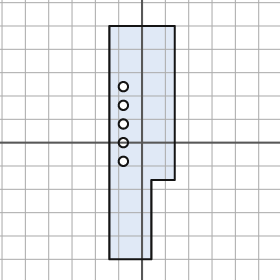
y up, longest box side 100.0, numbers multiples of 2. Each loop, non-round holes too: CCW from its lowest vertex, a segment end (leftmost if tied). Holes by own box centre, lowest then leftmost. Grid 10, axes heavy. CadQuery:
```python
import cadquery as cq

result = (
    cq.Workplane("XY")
    .moveTo(-14.0, -50.0)
    .lineTo(4.0, -50.0)
    .lineTo(4.0, -16.0)
    .lineTo(14.0, -16.0)
    .lineTo(14.0, 50.0)
    .lineTo(-14.0, 50.0)
    .close()
    .moveTo(-8.0, -8.0)
    .circle(2.0)
    .moveTo(-8.0, 0.0)
    .circle(2.0)
    .moveTo(-8.0, 8.0)
    .circle(2.0)
    .moveTo(-8.0, 16.0)
    .circle(2.0)
    .moveTo(-8.0, 24.0)
    .circle(2.0)
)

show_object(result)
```